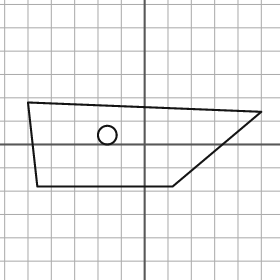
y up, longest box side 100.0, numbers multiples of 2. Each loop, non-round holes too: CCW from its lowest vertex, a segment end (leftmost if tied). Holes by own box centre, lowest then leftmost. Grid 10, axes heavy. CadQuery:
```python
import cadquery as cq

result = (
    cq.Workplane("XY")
    .moveTo(-46.0, -18.0)
    .lineTo(12.0, -18.0)
    .lineTo(50.0, 14.0)
    .lineTo(-50.0, 18.0)
    .close()
    .moveTo(-16.0, 4.0)
    .circle(4.0)
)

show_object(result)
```